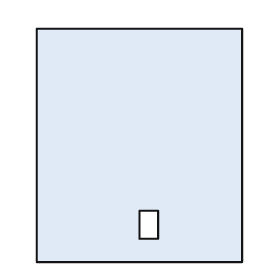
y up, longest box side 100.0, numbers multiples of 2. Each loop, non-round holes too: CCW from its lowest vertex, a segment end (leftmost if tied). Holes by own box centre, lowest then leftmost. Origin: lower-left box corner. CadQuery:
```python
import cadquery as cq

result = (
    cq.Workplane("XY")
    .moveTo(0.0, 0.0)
    .lineTo(88.0, 0.0)
    .lineTo(88.0, 100.0)
    .lineTo(0.0, 100.0)
    .close()
    .moveTo(44.0, 10.0)
    .lineTo(52.0, 10.0)
    .lineTo(52.0, 22.0)
    .lineTo(44.0, 22.0)
    .close()
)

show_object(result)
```